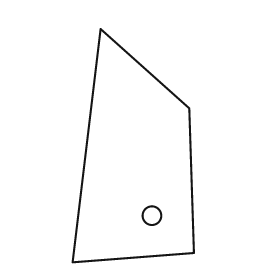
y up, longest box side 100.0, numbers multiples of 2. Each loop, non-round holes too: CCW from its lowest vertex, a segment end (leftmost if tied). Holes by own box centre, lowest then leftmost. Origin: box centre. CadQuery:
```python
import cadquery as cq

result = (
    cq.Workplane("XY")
    .moveTo(-26.0, -50.0)
    .lineTo(26.0, -46.0)
    .lineTo(24.0, 16.0)
    .lineTo(-14.0, 50.0)
    .close()
    .moveTo(8.0, -30.0)
    .circle(4.0)
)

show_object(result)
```